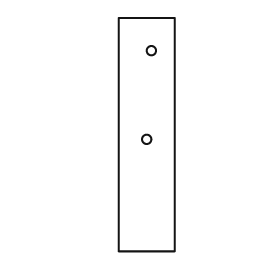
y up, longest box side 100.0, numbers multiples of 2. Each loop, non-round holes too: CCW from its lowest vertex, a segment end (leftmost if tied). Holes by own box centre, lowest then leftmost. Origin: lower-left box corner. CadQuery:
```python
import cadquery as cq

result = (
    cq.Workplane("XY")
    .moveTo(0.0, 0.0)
    .lineTo(24.0, 0.0)
    .lineTo(24.0, 100.0)
    .lineTo(0.0, 100.0)
    .close()
    .moveTo(12.0, 48.0)
    .circle(2.0)
    .moveTo(14.0, 86.0)
    .circle(2.0)
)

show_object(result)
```